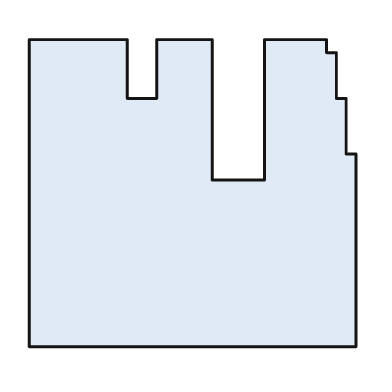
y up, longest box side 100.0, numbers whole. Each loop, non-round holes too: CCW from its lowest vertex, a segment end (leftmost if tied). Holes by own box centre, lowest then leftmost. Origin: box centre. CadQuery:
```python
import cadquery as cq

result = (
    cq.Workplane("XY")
    .moveTo(-50.0, -47.0)
    .lineTo(50.0, -47.0)
    .lineTo(50.0, 12.0)
    .lineTo(47.0, 12.0)
    .lineTo(47.0, 29.0)
    .lineTo(44.0, 29.0)
    .lineTo(44.0, 43.0)
    .lineTo(41.0, 43.0)
    .lineTo(41.0, 47.0)
    .lineTo(22.0, 47.0)
    .lineTo(22.0, 4.0)
    .lineTo(6.0, 4.0)
    .lineTo(6.0, 47.0)
    .lineTo(-11.0, 47.0)
    .lineTo(-11.0, 29.0)
    .lineTo(-20.0, 29.0)
    .lineTo(-20.0, 47.0)
    .lineTo(-50.0, 47.0)
    .close()
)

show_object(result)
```